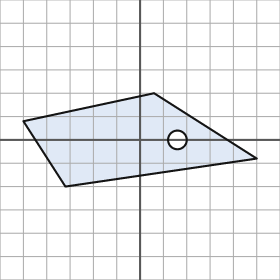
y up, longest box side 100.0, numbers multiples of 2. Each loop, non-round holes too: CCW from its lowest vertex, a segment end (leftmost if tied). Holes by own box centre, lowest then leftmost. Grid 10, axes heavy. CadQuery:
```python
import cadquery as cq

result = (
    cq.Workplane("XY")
    .moveTo(-32.0, -20.0)
    .lineTo(50.0, -8.0)
    .lineTo(6.0, 20.0)
    .lineTo(-50.0, 8.0)
    .close()
    .moveTo(16.0, 0.0)
    .circle(4.0)
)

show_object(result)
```